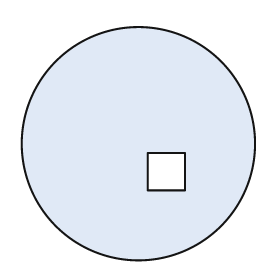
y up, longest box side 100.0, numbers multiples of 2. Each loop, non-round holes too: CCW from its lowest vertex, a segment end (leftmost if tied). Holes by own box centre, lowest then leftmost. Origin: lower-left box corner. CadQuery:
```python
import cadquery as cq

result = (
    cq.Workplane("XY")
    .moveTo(50.0, 50.0)
    .circle(50.0)
    .moveTo(54.0, 30.0)
    .lineTo(70.0, 30.0)
    .lineTo(70.0, 46.0)
    .lineTo(54.0, 46.0)
    .close()
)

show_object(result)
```